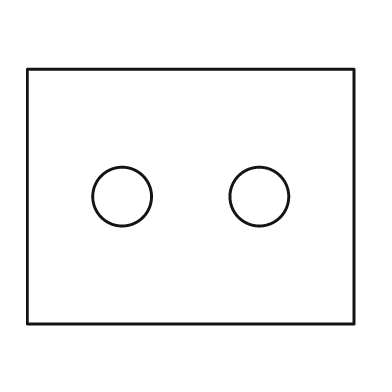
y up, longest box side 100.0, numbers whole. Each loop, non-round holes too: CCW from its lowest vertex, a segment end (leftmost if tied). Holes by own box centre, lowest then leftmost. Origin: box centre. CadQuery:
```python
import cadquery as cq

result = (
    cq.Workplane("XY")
    .moveTo(-50.0, -39.0)
    .lineTo(50.0, -39.0)
    .lineTo(50.0, 39.0)
    .lineTo(-50.0, 39.0)
    .close()
    .moveTo(-21.0, 0.0)
    .circle(9.0)
    .moveTo(21.0, 0.0)
    .circle(9.0)
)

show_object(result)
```